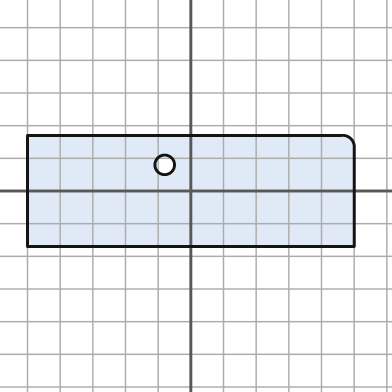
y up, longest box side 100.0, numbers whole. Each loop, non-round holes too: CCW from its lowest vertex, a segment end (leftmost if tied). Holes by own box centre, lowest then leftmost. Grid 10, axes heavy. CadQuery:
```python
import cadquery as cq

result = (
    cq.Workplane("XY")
    .moveTo(-50.0, -17.0)
    .lineTo(50.0, -17.0)
    .lineTo(50.0, 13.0)
    .threePointArc((49.0, 16.0), (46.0, 17.0))
    .lineTo(-50.0, 17.0)
    .close()
    .moveTo(-8.0, 8.0)
    .circle(3.0)
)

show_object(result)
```